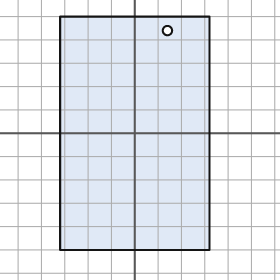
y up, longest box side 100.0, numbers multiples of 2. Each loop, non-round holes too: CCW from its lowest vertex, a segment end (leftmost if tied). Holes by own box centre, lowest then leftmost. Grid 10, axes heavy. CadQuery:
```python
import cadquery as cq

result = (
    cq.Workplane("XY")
    .moveTo(-32.0, -50.0)
    .lineTo(32.0, -50.0)
    .lineTo(32.0, 50.0)
    .lineTo(-32.0, 50.0)
    .close()
    .moveTo(14.0, 44.0)
    .circle(2.0)
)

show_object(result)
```